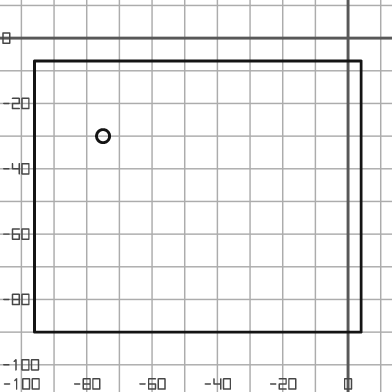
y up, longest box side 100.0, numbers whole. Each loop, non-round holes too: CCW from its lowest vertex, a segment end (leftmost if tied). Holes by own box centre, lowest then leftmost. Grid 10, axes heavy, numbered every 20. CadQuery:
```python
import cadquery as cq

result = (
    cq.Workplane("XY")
    .moveTo(-96.0, -90.0)
    .lineTo(4.0, -90.0)
    .lineTo(4.0, -7.0)
    .lineTo(-96.0, -7.0)
    .close()
    .moveTo(-75.0, -30.0)
    .circle(2.0)
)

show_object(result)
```